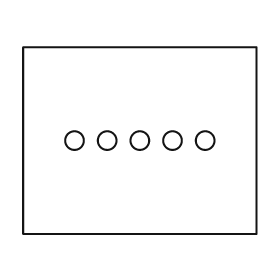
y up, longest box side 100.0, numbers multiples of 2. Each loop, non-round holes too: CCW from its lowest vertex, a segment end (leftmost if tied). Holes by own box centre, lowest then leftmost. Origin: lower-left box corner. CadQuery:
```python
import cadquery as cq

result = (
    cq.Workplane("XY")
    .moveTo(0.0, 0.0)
    .lineTo(100.0, 0.0)
    .lineTo(100.0, 80.0)
    .lineTo(0.0, 80.0)
    .close()
    .moveTo(22.0, 40.0)
    .circle(4.0)
    .moveTo(36.0, 40.0)
    .circle(4.0)
    .moveTo(50.0, 40.0)
    .circle(4.0)
    .moveTo(64.0, 40.0)
    .circle(4.0)
    .moveTo(78.0, 40.0)
    .circle(4.0)
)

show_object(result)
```